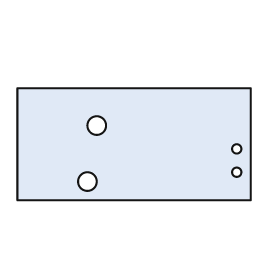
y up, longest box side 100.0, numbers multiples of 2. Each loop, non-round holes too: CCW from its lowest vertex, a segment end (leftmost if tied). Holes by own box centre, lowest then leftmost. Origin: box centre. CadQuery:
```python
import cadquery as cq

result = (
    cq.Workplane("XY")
    .moveTo(-50.0, -24.0)
    .lineTo(50.0, -24.0)
    .lineTo(50.0, 24.0)
    .lineTo(-50.0, 24.0)
    .close()
    .moveTo(-20.0, -16.0)
    .circle(4.0)
    .moveTo(44.0, -12.0)
    .circle(2.0)
    .moveTo(44.0, -2.0)
    .circle(2.0)
    .moveTo(-16.0, 8.0)
    .circle(4.0)
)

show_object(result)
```